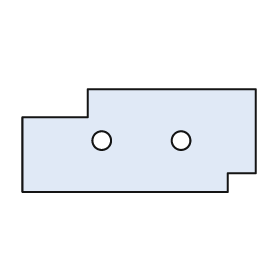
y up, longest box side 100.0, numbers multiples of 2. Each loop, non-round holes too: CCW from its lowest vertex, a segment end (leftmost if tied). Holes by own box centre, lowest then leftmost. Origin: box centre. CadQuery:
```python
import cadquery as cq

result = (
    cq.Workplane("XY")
    .moveTo(-50.0, -22.0)
    .lineTo(38.0, -22.0)
    .lineTo(38.0, -14.0)
    .lineTo(50.0, -14.0)
    .lineTo(50.0, 22.0)
    .lineTo(-22.0, 22.0)
    .lineTo(-22.0, 10.0)
    .lineTo(-50.0, 10.0)
    .close()
    .moveTo(-16.0, 0.0)
    .circle(4.0)
    .moveTo(18.0, 0.0)
    .circle(4.0)
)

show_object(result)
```